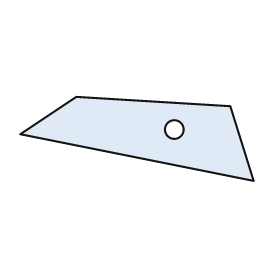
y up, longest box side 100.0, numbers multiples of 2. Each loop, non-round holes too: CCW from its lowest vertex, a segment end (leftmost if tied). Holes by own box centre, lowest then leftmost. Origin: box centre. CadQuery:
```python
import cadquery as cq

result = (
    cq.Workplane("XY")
    .moveTo(50.0, -18.0)
    .lineTo(40.0, 14.0)
    .lineTo(-26.0, 18.0)
    .lineTo(-50.0, 2.0)
    .close()
    .moveTo(16.0, 4.0)
    .circle(4.0)
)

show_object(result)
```